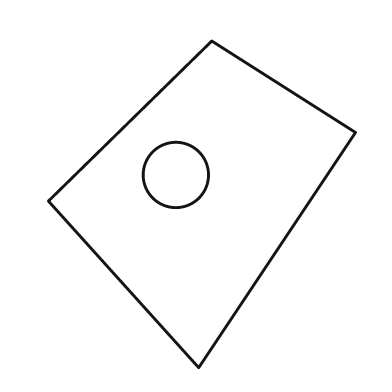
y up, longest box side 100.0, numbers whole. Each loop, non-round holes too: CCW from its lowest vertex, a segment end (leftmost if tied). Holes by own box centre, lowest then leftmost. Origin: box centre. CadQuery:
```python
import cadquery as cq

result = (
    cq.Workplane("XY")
    .moveTo(-1.0, -50.0)
    .lineTo(47.0, 22.0)
    .lineTo(3.0, 50.0)
    .lineTo(-47.0, 1.0)
    .close()
    .moveTo(-8.0, 9.0)
    .circle(10.0)
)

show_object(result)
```